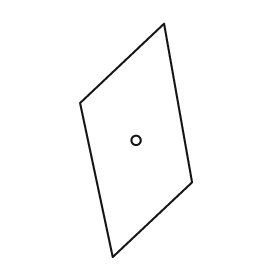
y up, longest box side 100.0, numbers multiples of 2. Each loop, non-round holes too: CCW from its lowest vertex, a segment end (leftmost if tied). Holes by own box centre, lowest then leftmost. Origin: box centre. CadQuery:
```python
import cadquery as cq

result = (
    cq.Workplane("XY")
    .moveTo(-10.0, -50.0)
    .lineTo(24.0, -18.0)
    .lineTo(12.0, 50.0)
    .lineTo(-24.0, 16.0)
    .close()
    .moveTo(0.0, 0.0)
    .circle(2.0)
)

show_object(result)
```